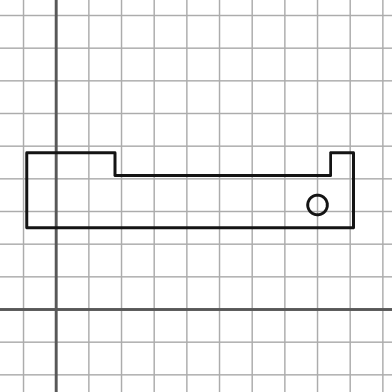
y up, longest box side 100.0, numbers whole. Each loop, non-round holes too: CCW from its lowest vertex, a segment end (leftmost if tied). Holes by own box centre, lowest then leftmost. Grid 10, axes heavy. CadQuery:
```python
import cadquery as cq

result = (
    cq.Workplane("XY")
    .moveTo(-9.0, 25.0)
    .lineTo(91.0, 25.0)
    .lineTo(91.0, 48.0)
    .lineTo(84.0, 48.0)
    .lineTo(84.0, 41.0)
    .lineTo(18.0, 41.0)
    .lineTo(18.0, 48.0)
    .lineTo(-9.0, 48.0)
    .close()
    .moveTo(80.0, 32.0)
    .circle(3.0)
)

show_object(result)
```